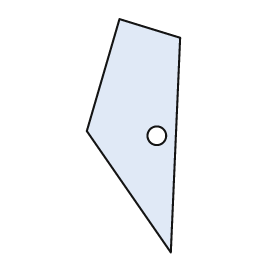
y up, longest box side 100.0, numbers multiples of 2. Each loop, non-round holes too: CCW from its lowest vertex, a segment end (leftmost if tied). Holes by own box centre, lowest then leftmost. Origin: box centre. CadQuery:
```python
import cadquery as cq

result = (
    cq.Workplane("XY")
    .moveTo(16.0, -50.0)
    .lineTo(20.0, 42.0)
    .lineTo(-6.0, 50.0)
    .lineTo(-20.0, 2.0)
    .close()
    .moveTo(10.0, 0.0)
    .circle(4.0)
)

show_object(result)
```